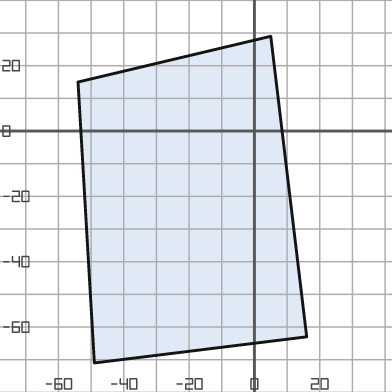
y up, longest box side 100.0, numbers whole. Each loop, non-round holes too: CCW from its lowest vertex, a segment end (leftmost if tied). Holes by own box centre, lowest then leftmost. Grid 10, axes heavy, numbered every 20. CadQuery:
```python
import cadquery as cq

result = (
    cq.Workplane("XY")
    .moveTo(-49.0, -71.0)
    .lineTo(16.0, -63.0)
    .lineTo(5.0, 29.0)
    .lineTo(-54.0, 15.0)
    .close()
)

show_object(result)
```